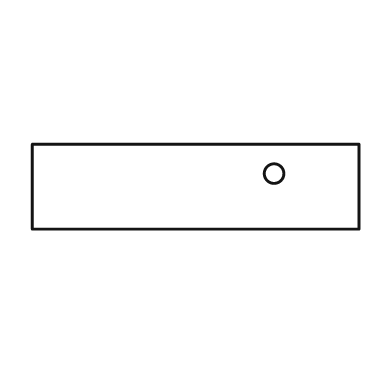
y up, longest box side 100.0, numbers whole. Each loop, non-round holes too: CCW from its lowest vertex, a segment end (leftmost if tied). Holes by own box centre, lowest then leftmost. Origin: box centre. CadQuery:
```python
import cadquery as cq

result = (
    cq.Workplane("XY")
    .moveTo(-50.0, -13.0)
    .lineTo(50.0, -13.0)
    .lineTo(50.0, 13.0)
    .lineTo(-50.0, 13.0)
    .close()
    .moveTo(24.0, 4.0)
    .circle(3.0)
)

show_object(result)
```